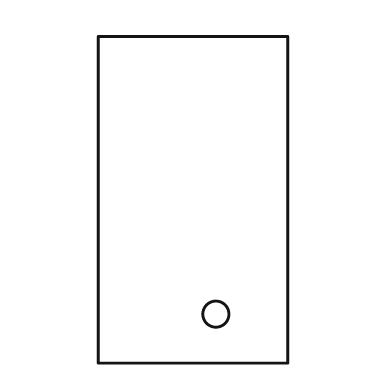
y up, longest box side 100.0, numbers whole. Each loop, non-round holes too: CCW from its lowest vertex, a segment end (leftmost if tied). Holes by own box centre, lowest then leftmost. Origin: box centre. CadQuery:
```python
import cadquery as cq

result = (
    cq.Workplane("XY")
    .moveTo(-29.0, -50.0)
    .lineTo(29.0, -50.0)
    .lineTo(29.0, 50.0)
    .lineTo(-29.0, 50.0)
    .close()
    .moveTo(7.0, -35.0)
    .circle(4.0)
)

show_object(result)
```